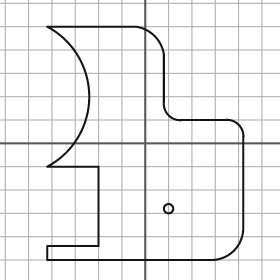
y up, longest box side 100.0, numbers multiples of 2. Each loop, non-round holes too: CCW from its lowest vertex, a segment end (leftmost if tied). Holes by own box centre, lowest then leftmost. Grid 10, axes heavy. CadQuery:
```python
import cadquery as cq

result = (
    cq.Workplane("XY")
    .moveTo(-42.0, -50.0)
    .lineTo(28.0, -50.0)
    .threePointArc((38.0, -46.0), (42.0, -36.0))
    .lineTo(42.0, 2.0)
    .threePointArc((40.0, 8.0), (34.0, 10.0))
    .lineTo(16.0, 10.0)
    .threePointArc((10.0, 12.0), (8.0, 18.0))
    .lineTo(8.0, 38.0)
    .threePointArc((4.0, 46.0), (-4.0, 50.0))
    .lineTo(-42.0, 50.0)
    .threePointArc((-24.0, 20.0), (-42.0, -10.0))
    .lineTo(-20.0, -10.0)
    .lineTo(-20.0, -44.0)
    .lineTo(-42.0, -44.0)
    .close()
    .moveTo(10.0, -28.0)
    .circle(2.0)
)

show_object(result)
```